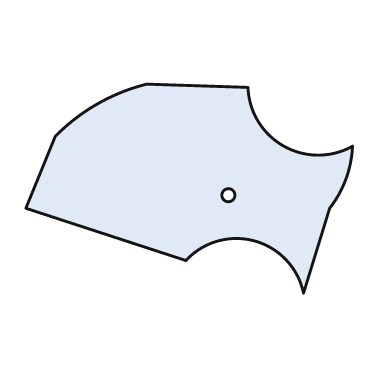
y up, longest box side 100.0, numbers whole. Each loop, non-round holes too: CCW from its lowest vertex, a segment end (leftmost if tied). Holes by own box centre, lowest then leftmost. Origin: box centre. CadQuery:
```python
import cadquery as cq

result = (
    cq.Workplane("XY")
    .moveTo(35.0, -32.0)
    .lineTo(43.0, -6.0)
    .threePointArc((48.0, 3.0), (50.0, 13.0))
    .threePointArc((29.0, 13.0), (18.0, 31.0))
    .lineTo(-13.0, 32.0)
    .threePointArc((-28.0, 26.0), (-41.0, 16.0))
    .lineTo(-50.0, -6.0)
    .lineTo(-1.0, -22.0)
    .threePointArc((20.0, -16.0), (35.0, -32.0))
    .close()
    .moveTo(12.0, -2.0)
    .circle(2.0)
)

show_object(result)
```